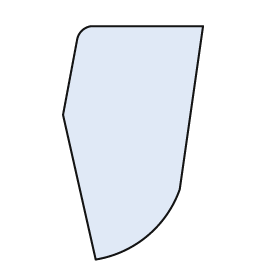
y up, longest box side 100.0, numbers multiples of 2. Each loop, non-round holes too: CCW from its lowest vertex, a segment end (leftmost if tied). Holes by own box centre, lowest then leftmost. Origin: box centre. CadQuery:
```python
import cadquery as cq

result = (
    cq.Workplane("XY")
    .moveTo(-16.0, -50.0)
    .threePointArc((6.0, -40.0), (20.0, -20.0))
    .lineTo(30.0, 50.0)
    .lineTo(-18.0, 50.0)
    .threePointArc((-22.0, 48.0), (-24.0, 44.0))
    .lineTo(-30.0, 12.0)
    .close()
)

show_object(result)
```